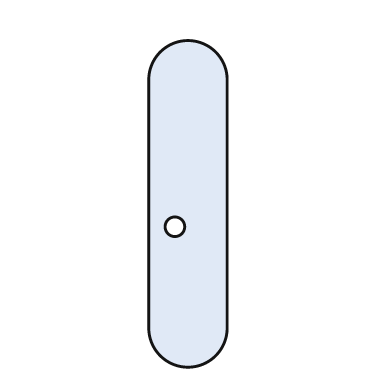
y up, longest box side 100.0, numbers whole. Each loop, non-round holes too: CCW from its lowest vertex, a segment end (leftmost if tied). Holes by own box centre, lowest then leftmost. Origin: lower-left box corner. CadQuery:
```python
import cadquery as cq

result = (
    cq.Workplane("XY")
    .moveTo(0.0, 12.0)
    .threePointArc((12.0, 0.0), (24.0, 12.0))
    .lineTo(24.0, 88.0)
    .threePointArc((12.0, 100.0), (0.0, 88.0))
    .close()
    .moveTo(8.0, 43.0)
    .circle(3.0)
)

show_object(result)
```